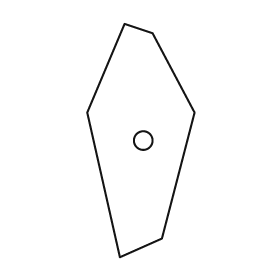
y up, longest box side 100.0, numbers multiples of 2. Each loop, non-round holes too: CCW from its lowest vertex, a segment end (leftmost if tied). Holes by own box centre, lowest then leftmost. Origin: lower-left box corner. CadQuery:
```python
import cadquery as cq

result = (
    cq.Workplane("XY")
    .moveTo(14.0, 0.0)
    .lineTo(32.0, 8.0)
    .lineTo(46.0, 62.0)
    .lineTo(28.0, 96.0)
    .lineTo(16.0, 100.0)
    .lineTo(0.0, 62.0)
    .close()
    .moveTo(24.0, 50.0)
    .circle(4.0)
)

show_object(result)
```